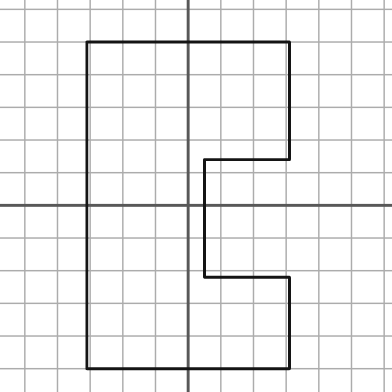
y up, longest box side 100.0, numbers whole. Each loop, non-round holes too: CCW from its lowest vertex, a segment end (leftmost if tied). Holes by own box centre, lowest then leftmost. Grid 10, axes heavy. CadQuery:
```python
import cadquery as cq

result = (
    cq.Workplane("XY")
    .moveTo(-31.0, -50.0)
    .lineTo(31.0, -50.0)
    .lineTo(31.0, -22.0)
    .lineTo(5.0, -22.0)
    .lineTo(5.0, 14.0)
    .lineTo(31.0, 14.0)
    .lineTo(31.0, 50.0)
    .lineTo(-31.0, 50.0)
    .close()
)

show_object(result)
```